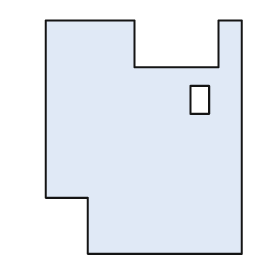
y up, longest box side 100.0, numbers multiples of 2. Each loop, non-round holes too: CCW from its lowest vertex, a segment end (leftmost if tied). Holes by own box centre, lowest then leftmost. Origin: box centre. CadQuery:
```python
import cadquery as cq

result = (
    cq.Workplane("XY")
    .moveTo(-24.0, -50.0)
    .lineTo(42.0, -50.0)
    .lineTo(42.0, 50.0)
    .lineTo(32.0, 50.0)
    .lineTo(32.0, 30.0)
    .lineTo(-4.0, 30.0)
    .lineTo(-4.0, 50.0)
    .lineTo(-42.0, 50.0)
    .lineTo(-42.0, -26.0)
    .lineTo(-24.0, -26.0)
    .close()
    .moveTo(20.0, 10.0)
    .lineTo(28.0, 10.0)
    .lineTo(28.0, 22.0)
    .lineTo(20.0, 22.0)
    .close()
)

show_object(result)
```